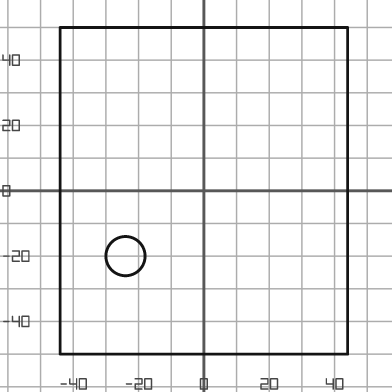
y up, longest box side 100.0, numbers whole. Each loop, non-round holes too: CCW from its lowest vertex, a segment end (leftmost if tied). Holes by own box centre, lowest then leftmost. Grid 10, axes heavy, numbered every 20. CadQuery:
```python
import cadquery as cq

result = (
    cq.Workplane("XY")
    .moveTo(-44.0, -50.0)
    .lineTo(44.0, -50.0)
    .lineTo(44.0, 50.0)
    .lineTo(-44.0, 50.0)
    .close()
    .moveTo(-24.0, -20.0)
    .circle(6.0)
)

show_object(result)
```